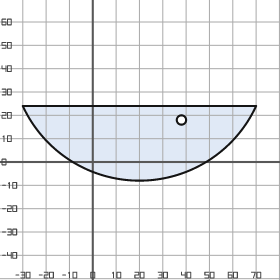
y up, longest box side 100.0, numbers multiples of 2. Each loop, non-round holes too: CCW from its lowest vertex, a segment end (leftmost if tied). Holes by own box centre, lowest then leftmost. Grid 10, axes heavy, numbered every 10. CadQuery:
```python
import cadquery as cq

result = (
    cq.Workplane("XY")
    .moveTo(-30.0, 24.0)
    .threePointArc((20.0, -8.0), (70.0, 24.0))
    .close()
    .moveTo(38.0, 18.0)
    .circle(2.0)
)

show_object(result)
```